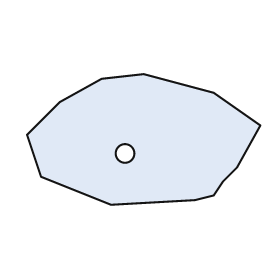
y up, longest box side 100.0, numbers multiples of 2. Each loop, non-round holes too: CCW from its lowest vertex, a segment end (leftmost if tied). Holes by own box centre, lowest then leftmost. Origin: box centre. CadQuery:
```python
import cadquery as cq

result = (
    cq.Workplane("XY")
    .moveTo(-14.0, -28.0)
    .lineTo(22.0, -26.0)
    .lineTo(30.0, -24.0)
    .lineTo(34.0, -18.0)
    .lineTo(40.0, -12.0)
    .lineTo(50.0, 6.0)
    .lineTo(30.0, 20.0)
    .lineTo(0.0, 28.0)
    .lineTo(-18.0, 26.0)
    .lineTo(-36.0, 16.0)
    .lineTo(-50.0, 2.0)
    .lineTo(-44.0, -16.0)
    .close()
    .moveTo(-8.0, -6.0)
    .circle(4.0)
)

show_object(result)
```